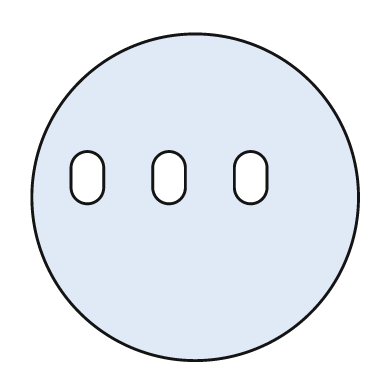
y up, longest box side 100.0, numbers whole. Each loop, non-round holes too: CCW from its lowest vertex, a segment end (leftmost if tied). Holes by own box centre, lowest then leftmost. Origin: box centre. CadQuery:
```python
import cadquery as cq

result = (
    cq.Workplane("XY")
    .moveTo(0.0, 0.0)
    .circle(50.0)
    .moveTo(-38.0, 3.0)
    .threePointArc((-33.0, -2.0), (-28.0, 3.0))
    .lineTo(-28.0, 9.0)
    .threePointArc((-33.0, 14.0), (-38.0, 9.0))
    .close()
    .moveTo(-13.0, 3.0)
    .threePointArc((-8.0, -2.0), (-3.0, 3.0))
    .lineTo(-3.0, 9.0)
    .threePointArc((-8.0, 14.0), (-13.0, 9.0))
    .close()
    .moveTo(12.0, 3.0)
    .threePointArc((17.0, -2.0), (22.0, 3.0))
    .lineTo(22.0, 9.0)
    .threePointArc((17.0, 14.0), (12.0, 9.0))
    .close()
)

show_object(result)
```